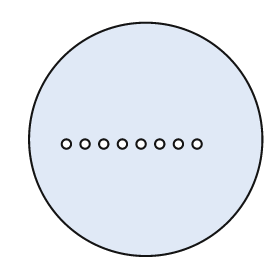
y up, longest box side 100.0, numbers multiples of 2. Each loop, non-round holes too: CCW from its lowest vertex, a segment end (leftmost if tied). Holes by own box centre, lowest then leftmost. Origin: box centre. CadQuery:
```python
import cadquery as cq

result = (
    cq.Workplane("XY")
    .moveTo(0.0, 0.0)
    .circle(50.0)
    .moveTo(-34.0, -2.0)
    .circle(2.0)
    .moveTo(-26.0, -2.0)
    .circle(2.0)
    .moveTo(-18.0, -2.0)
    .circle(2.0)
    .moveTo(-10.0, -2.0)
    .circle(2.0)
    .moveTo(-2.0, -2.0)
    .circle(2.0)
    .moveTo(6.0, -2.0)
    .circle(2.0)
    .moveTo(14.0, -2.0)
    .circle(2.0)
    .moveTo(22.0, -2.0)
    .circle(2.0)
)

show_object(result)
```